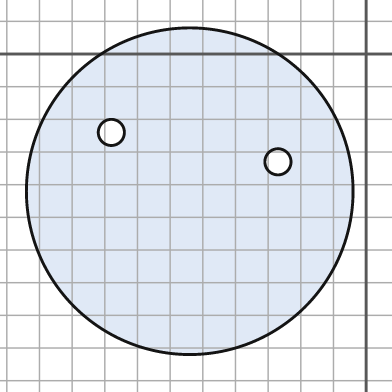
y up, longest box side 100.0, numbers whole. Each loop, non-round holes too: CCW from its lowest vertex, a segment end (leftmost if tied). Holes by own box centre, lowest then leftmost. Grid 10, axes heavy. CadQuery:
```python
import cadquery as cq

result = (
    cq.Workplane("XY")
    .moveTo(-54.0, -42.0)
    .circle(50.0)
    .moveTo(-27.0, -33.0)
    .circle(4.0)
    .moveTo(-78.0, -24.0)
    .circle(4.0)
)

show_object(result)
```